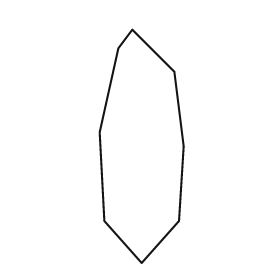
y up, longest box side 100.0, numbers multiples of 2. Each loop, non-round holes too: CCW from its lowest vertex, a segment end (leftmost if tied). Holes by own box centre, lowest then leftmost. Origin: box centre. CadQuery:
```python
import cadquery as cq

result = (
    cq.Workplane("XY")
    .moveTo(0.0, -50.0)
    .lineTo(16.0, -32.0)
    .lineTo(18.0, 0.0)
    .lineTo(14.0, 32.0)
    .lineTo(-4.0, 50.0)
    .lineTo(-10.0, 42.0)
    .lineTo(-18.0, 6.0)
    .lineTo(-16.0, -32.0)
    .close()
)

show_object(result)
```